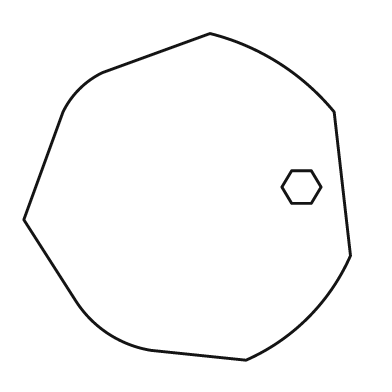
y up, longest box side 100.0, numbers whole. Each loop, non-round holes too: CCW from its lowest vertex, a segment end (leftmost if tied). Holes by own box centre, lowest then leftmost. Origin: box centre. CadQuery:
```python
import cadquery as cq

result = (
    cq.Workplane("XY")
    .moveTo(18.0, -50.0)
    .threePointArc((37.0, -37.0), (50.0, -18.0))
    .lineTo(45.0, 26.0)
    .threePointArc((28.0, 41.0), (7.0, 50.0))
    .lineTo(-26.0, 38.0)
    .threePointArc((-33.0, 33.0), (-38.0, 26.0))
    .lineTo(-50.0, -7.0)
    .lineTo(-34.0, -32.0)
    .threePointArc((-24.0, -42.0), (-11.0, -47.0))
    .close()
    .moveTo(32.0, -2.0)
    .lineTo(38.0, -2.0)
    .lineTo(41.0, 3.0)
    .lineTo(38.0, 8.0)
    .lineTo(32.0, 8.0)
    .lineTo(29.0, 3.0)
    .close()
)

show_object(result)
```